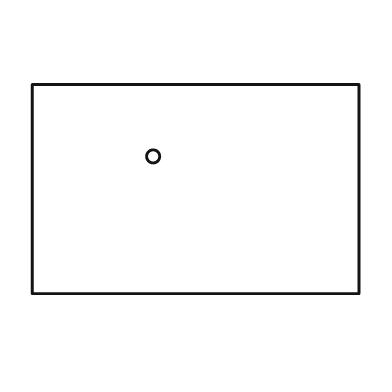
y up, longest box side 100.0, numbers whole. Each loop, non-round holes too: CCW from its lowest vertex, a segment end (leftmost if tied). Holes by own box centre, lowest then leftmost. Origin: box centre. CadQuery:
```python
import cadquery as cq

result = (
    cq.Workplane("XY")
    .moveTo(-50.0, -32.0)
    .lineTo(50.0, -32.0)
    .lineTo(50.0, 32.0)
    .lineTo(-50.0, 32.0)
    .close()
    .moveTo(-13.0, 10.0)
    .circle(2.0)
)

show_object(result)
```